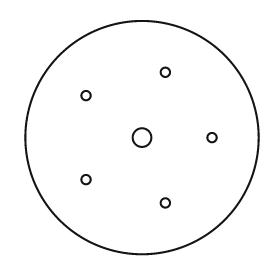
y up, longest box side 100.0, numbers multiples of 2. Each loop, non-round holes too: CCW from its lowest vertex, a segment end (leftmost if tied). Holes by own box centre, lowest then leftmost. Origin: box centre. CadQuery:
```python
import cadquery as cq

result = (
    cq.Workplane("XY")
    .moveTo(0.0, 0.0)
    .circle(50.0)
    .moveTo(10.0, -28.0)
    .circle(2.0)
    .moveTo(-24.0, -18.0)
    .circle(2.0)
    .moveTo(0.0, 0.0)
    .circle(4.0)
    .moveTo(30.0, 0.0)
    .circle(2.0)
    .moveTo(-24.0, 18.0)
    .circle(2.0)
    .moveTo(10.0, 28.0)
    .circle(2.0)
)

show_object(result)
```